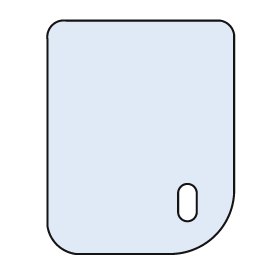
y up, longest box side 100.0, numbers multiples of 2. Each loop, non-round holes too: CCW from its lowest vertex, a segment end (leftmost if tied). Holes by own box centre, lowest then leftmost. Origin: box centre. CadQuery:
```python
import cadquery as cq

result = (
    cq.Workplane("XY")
    .moveTo(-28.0, -50.0)
    .lineTo(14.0, -50.0)
    .threePointArc((32.0, -42.0), (40.0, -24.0))
    .lineTo(40.0, 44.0)
    .threePointArc((38.0, 48.0), (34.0, 50.0))
    .lineTo(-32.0, 50.0)
    .threePointArc((-38.0, 48.0), (-40.0, 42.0))
    .lineTo(-40.0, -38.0)
    .threePointArc((-36.0, -46.0), (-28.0, -50.0))
    .close()
    .moveTo(16.0, -32.0)
    .threePointArc((20.0, -36.0), (24.0, -32.0))
    .lineTo(24.0, -24.0)
    .threePointArc((20.0, -20.0), (16.0, -24.0))
    .close()
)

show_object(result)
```